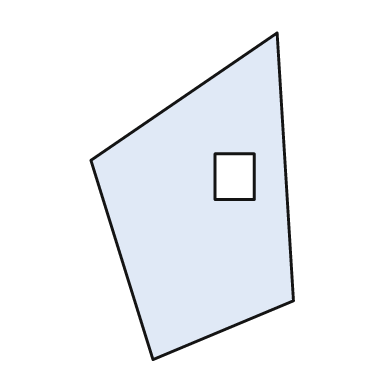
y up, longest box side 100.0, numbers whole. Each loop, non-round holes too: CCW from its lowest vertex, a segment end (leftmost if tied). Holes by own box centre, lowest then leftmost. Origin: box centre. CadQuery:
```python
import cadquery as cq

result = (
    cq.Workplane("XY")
    .moveTo(-12.0, -50.0)
    .lineTo(31.0, -32.0)
    .lineTo(26.0, 50.0)
    .lineTo(-31.0, 11.0)
    .close()
    .moveTo(7.0, -1.0)
    .lineTo(19.0, -1.0)
    .lineTo(19.0, 13.0)
    .lineTo(7.0, 13.0)
    .close()
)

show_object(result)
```